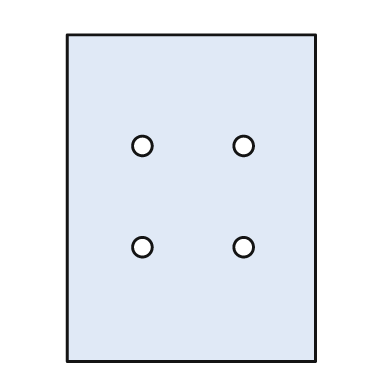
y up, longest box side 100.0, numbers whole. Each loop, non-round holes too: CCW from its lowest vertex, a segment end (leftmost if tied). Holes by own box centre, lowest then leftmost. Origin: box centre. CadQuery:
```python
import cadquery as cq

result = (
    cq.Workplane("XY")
    .moveTo(-38.0, -50.0)
    .lineTo(38.0, -50.0)
    .lineTo(38.0, 50.0)
    .lineTo(-38.0, 50.0)
    .close()
    .moveTo(-15.0, -15.0)
    .circle(3.0)
    .moveTo(16.0, -15.0)
    .circle(3.0)
    .moveTo(-15.0, 16.0)
    .circle(3.0)
    .moveTo(16.0, 16.0)
    .circle(3.0)
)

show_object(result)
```